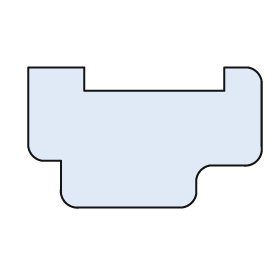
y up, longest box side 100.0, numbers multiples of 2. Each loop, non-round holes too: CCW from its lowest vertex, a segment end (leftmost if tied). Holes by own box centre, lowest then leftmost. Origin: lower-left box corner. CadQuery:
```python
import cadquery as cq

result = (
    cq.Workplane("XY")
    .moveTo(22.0, 0.0)
    .lineTo(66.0, 0.0)
    .threePointArc((70.0, 2.0), (72.0, 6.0))
    .lineTo(72.0, 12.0)
    .threePointArc((74.0, 16.0), (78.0, 18.0))
    .lineTo(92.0, 18.0)
    .threePointArc((98.0, 20.0), (100.0, 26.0))
    .lineTo(100.0, 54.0)
    .threePointArc((98.0, 58.0), (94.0, 60.0))
    .lineTo(84.0, 60.0)
    .lineTo(84.0, 50.0)
    .lineTo(24.0, 50.0)
    .lineTo(24.0, 60.0)
    .lineTo(0.0, 60.0)
    .lineTo(0.0, 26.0)
    .threePointArc((2.0, 22.0), (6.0, 20.0))
    .lineTo(14.0, 20.0)
    .lineTo(14.0, 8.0)
    .threePointArc((16.0, 2.0), (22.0, 0.0))
    .close()
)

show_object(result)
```